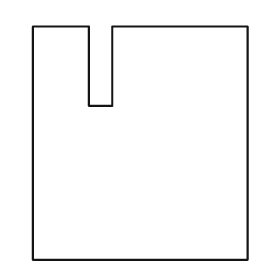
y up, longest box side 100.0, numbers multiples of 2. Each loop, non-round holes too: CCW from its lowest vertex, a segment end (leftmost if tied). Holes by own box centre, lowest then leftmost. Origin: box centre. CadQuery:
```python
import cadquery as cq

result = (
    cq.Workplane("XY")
    .moveTo(-46.0, -50.0)
    .lineTo(46.0, -50.0)
    .lineTo(46.0, 50.0)
    .lineTo(-12.0, 50.0)
    .lineTo(-12.0, 16.0)
    .lineTo(-22.0, 16.0)
    .lineTo(-22.0, 50.0)
    .lineTo(-46.0, 50.0)
    .close()
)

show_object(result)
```